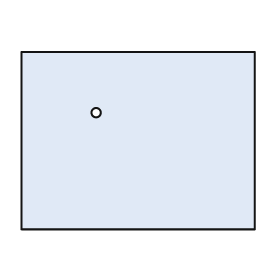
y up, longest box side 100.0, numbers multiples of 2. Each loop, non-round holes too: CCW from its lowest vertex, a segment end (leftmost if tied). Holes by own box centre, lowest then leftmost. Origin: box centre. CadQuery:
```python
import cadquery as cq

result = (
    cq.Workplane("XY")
    .moveTo(-50.0, -38.0)
    .lineTo(50.0, -38.0)
    .lineTo(50.0, 38.0)
    .lineTo(-50.0, 38.0)
    .close()
    .moveTo(-18.0, 12.0)
    .circle(2.0)
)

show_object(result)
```